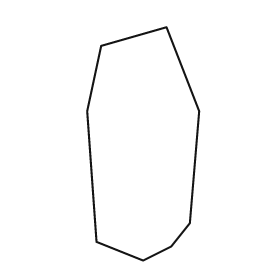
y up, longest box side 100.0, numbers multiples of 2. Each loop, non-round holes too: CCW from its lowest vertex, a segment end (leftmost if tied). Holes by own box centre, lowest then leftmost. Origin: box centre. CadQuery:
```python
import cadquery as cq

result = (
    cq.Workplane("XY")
    .moveTo(0.0, -50.0)
    .lineTo(12.0, -44.0)
    .lineTo(20.0, -34.0)
    .lineTo(24.0, 14.0)
    .lineTo(10.0, 50.0)
    .lineTo(-18.0, 42.0)
    .lineTo(-24.0, 14.0)
    .lineTo(-20.0, -42.0)
    .close()
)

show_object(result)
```